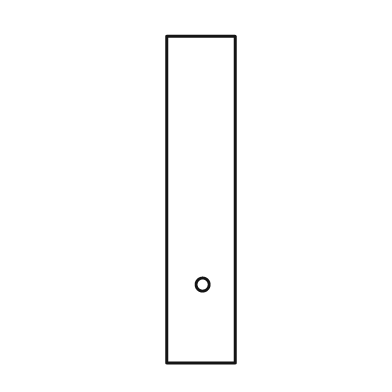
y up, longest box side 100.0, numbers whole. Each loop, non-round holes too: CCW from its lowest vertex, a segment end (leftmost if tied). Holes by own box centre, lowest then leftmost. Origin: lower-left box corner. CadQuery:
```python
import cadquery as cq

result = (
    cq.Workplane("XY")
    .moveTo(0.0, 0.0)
    .lineTo(21.0, 0.0)
    .lineTo(21.0, 100.0)
    .lineTo(0.0, 100.0)
    .close()
    .moveTo(11.0, 24.0)
    .circle(2.0)
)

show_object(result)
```